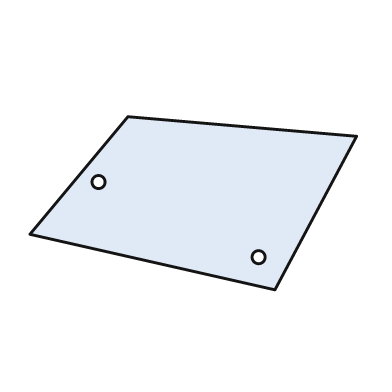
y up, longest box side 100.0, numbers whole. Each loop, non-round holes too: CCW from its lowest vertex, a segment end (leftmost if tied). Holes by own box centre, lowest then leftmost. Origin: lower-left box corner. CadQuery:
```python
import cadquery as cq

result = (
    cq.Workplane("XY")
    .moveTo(75.0, 0.0)
    .lineTo(100.0, 47.0)
    .lineTo(30.0, 53.0)
    .lineTo(0.0, 17.0)
    .close()
    .moveTo(70.0, 10.0)
    .circle(2.0)
    .moveTo(21.0, 33.0)
    .circle(2.0)
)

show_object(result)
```